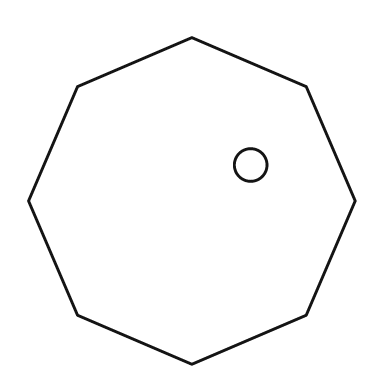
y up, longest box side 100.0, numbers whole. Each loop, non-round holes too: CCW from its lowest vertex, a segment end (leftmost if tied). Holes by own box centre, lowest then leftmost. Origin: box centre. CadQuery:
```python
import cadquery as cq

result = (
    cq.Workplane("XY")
    .moveTo(0.0, -50.0)
    .lineTo(35.0, -35.0)
    .lineTo(50.0, 0.0)
    .lineTo(35.0, 35.0)
    .lineTo(0.0, 50.0)
    .lineTo(-35.0, 35.0)
    .lineTo(-50.0, 0.0)
    .lineTo(-35.0, -35.0)
    .close()
    .moveTo(18.0, 11.0)
    .circle(5.0)
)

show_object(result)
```